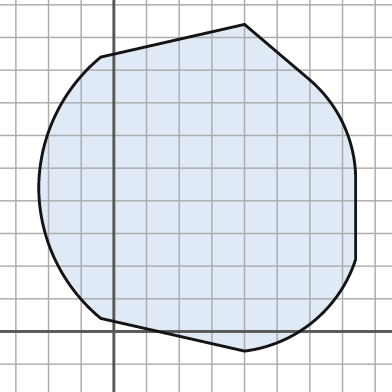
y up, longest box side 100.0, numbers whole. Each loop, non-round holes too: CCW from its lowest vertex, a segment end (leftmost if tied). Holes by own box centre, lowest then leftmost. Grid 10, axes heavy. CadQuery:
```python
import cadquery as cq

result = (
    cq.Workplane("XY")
    .moveTo(40.0, -6.0)
    .threePointArc((61.0, 3.0), (74.0, 22.0))
    .lineTo(74.0, 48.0)
    .threePointArc((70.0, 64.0), (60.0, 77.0))
    .lineTo(40.0, 94.0)
    .lineTo(-4.0, 84.0)
    .threePointArc((-18.0, 66.0), (-23.0, 44.0))
    .threePointArc((-18.0, 22.0), (-4.0, 4.0))
    .close()
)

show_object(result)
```